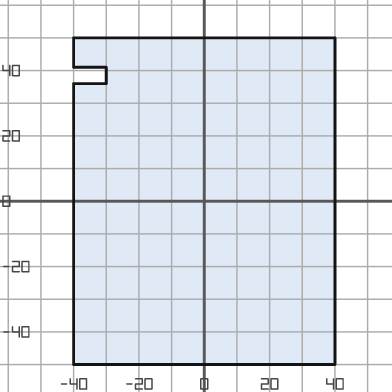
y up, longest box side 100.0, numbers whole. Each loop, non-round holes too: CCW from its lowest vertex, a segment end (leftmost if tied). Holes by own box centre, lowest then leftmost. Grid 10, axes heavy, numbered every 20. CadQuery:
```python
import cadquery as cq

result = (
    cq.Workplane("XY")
    .moveTo(-40.0, -50.0)
    .lineTo(40.0, -50.0)
    .lineTo(40.0, 50.0)
    .lineTo(-40.0, 50.0)
    .lineTo(-40.0, 41.0)
    .lineTo(-30.0, 41.0)
    .lineTo(-30.0, 36.0)
    .lineTo(-40.0, 36.0)
    .close()
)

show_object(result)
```